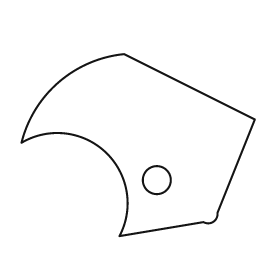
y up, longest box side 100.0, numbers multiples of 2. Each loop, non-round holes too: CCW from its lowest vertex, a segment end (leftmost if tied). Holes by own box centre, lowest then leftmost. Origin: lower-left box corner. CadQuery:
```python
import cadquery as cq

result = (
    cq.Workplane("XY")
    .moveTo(42.0, 0.0)
    .lineTo(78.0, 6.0)
    .threePointArc((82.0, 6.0), (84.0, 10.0))
    .lineTo(100.0, 50.0)
    .lineTo(44.0, 78.0)
    .threePointArc((16.0, 66.0), (0.0, 40.0))
    .threePointArc((36.0, 36.0), (42.0, 0.0))
    .close()
    .moveTo(58.0, 24.0)
    .circle(6.0)
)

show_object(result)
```